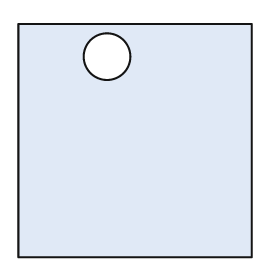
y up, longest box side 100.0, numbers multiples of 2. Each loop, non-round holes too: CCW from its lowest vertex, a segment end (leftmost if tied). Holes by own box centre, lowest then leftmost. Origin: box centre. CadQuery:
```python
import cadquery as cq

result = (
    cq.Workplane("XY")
    .moveTo(-50.0, -50.0)
    .lineTo(50.0, -50.0)
    .lineTo(50.0, 50.0)
    .lineTo(-50.0, 50.0)
    .close()
    .moveTo(-12.0, 36.0)
    .circle(10.0)
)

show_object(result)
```